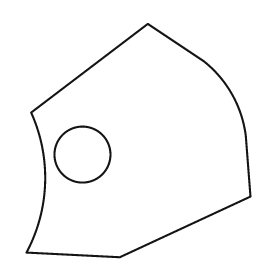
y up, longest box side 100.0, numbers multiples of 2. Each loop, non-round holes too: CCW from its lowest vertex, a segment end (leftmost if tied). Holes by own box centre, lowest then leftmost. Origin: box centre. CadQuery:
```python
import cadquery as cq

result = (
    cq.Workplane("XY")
    .moveTo(-8.0, -50.0)
    .lineTo(48.0, -24.0)
    .lineTo(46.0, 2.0)
    .threePointArc((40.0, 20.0), (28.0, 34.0))
    .lineTo(4.0, 50.0)
    .lineTo(-46.0, 12.0)
    .threePointArc((-40.0, -18.0), (-48.0, -48.0))
    .close()
    .moveTo(-24.0, -6.0)
    .circle(12.0)
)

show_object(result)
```